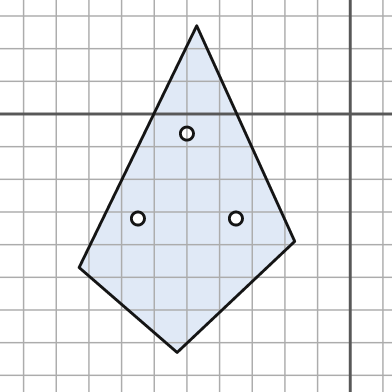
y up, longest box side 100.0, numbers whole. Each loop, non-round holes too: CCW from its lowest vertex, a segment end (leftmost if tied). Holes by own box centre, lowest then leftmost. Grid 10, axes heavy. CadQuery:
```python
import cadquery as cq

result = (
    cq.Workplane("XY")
    .moveTo(-53.0, -73.0)
    .lineTo(-17.0, -39.0)
    .lineTo(-47.0, 27.0)
    .lineTo(-83.0, -47.0)
    .close()
    .moveTo(-65.0, -32.0)
    .circle(2.0)
    .moveTo(-35.0, -32.0)
    .circle(2.0)
    .moveTo(-50.0, -6.0)
    .circle(2.0)
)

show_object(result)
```